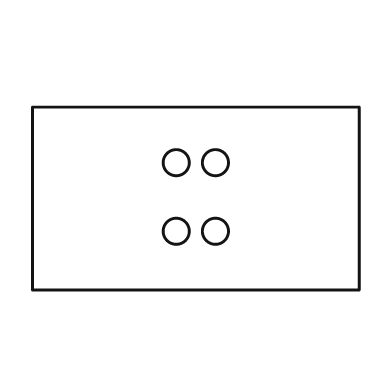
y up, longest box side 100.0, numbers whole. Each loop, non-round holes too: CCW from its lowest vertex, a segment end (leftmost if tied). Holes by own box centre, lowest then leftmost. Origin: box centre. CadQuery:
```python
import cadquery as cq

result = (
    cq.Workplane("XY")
    .moveTo(-50.0, -28.0)
    .lineTo(50.0, -28.0)
    .lineTo(50.0, 28.0)
    .lineTo(-50.0, 28.0)
    .close()
    .moveTo(-6.0, -10.0)
    .circle(4.0)
    .moveTo(6.0, -10.0)
    .circle(4.0)
    .moveTo(-6.0, 11.0)
    .circle(4.0)
    .moveTo(6.0, 11.0)
    .circle(4.0)
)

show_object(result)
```